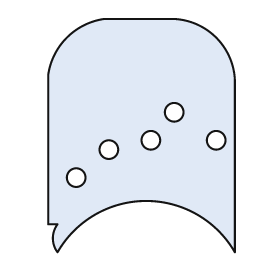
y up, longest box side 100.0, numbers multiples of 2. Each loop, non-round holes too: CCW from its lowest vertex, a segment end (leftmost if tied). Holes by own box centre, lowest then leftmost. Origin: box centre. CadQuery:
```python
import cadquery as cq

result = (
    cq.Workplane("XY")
    .moveTo(-36.0, -50.0)
    .threePointArc((2.0, -28.0), (40.0, -50.0))
    .lineTo(40.0, 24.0)
    .threePointArc((32.0, 42.0), (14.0, 50.0))
    .lineTo(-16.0, 50.0)
    .threePointArc((-32.0, 42.0), (-40.0, 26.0))
    .lineTo(-40.0, -38.0)
    .lineTo(-36.0, -38.0)
    .threePointArc((-38.0, -44.0), (-36.0, -50.0))
    .close()
    .moveTo(-28.0, -18.0)
    .circle(4.0)
    .moveTo(-14.0, -6.0)
    .circle(4.0)
    .moveTo(4.0, -2.0)
    .circle(4.0)
    .moveTo(32.0, -2.0)
    .circle(4.0)
    .moveTo(14.0, 10.0)
    .circle(4.0)
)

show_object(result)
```